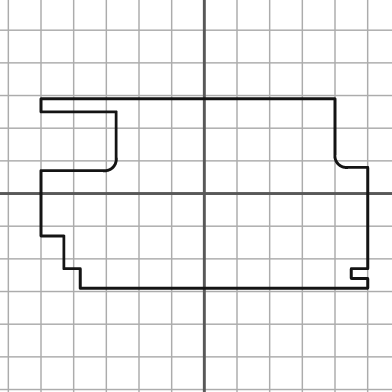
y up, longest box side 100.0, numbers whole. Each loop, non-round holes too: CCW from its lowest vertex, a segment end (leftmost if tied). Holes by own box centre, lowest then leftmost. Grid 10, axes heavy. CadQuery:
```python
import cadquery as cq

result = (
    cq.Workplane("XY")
    .moveTo(-38.0, -29.0)
    .lineTo(50.0, -29.0)
    .lineTo(50.0, -26.0)
    .lineTo(45.0, -26.0)
    .lineTo(45.0, -23.0)
    .lineTo(50.0, -23.0)
    .lineTo(50.0, 8.0)
    .lineTo(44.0, 8.0)
    .threePointArc((41.0, 9.0), (40.0, 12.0))
    .lineTo(40.0, 29.0)
    .lineTo(-50.0, 29.0)
    .lineTo(-50.0, 25.0)
    .lineTo(-27.0, 25.0)
    .lineTo(-27.0, 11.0)
    .threePointArc((-28.0, 8.0), (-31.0, 7.0))
    .lineTo(-50.0, 7.0)
    .lineTo(-50.0, -13.0)
    .lineTo(-43.0, -13.0)
    .lineTo(-43.0, -23.0)
    .lineTo(-38.0, -23.0)
    .close()
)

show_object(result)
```